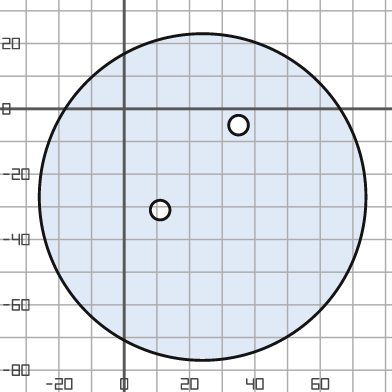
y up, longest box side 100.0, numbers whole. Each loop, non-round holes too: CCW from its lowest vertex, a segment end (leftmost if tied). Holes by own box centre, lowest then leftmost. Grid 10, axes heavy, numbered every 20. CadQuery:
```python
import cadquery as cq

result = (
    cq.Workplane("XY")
    .moveTo(24.0, -27.0)
    .circle(50.0)
    .moveTo(11.0, -31.0)
    .circle(3.0)
    .moveTo(35.0, -5.0)
    .circle(3.0)
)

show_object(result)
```